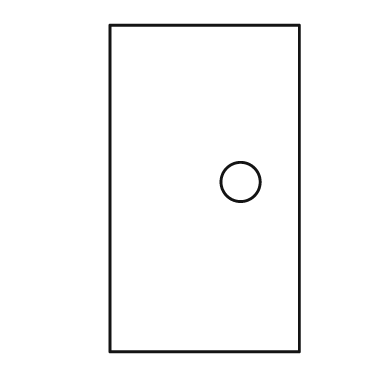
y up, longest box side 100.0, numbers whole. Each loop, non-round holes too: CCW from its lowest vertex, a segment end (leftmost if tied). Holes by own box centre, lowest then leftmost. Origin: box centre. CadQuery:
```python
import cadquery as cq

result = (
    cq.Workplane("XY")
    .moveTo(-29.0, -50.0)
    .lineTo(29.0, -50.0)
    .lineTo(29.0, 50.0)
    .lineTo(-29.0, 50.0)
    .close()
    .moveTo(11.0, 2.0)
    .circle(6.0)
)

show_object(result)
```